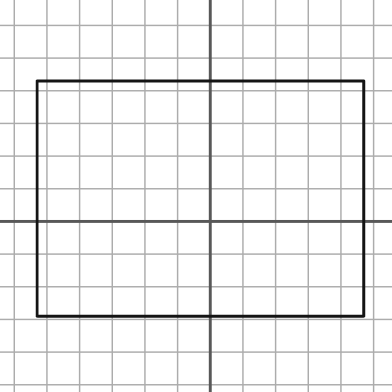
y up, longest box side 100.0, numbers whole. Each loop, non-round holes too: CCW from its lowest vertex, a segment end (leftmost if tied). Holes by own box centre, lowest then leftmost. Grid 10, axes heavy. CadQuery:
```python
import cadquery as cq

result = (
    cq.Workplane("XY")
    .moveTo(-53.0, -29.0)
    .lineTo(47.0, -29.0)
    .lineTo(47.0, 43.0)
    .lineTo(-53.0, 43.0)
    .close()
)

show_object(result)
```